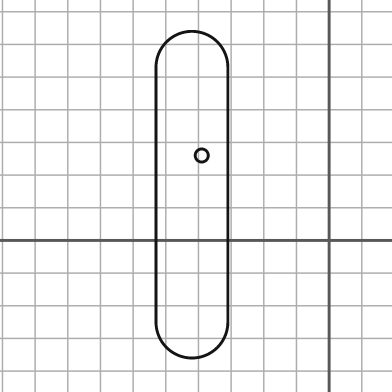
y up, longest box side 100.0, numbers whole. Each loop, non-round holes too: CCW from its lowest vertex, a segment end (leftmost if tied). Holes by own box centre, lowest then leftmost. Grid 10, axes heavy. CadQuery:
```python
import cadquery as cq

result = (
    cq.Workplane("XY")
    .moveTo(-53.0, -25.0)
    .threePointArc((-42.0, -36.0), (-31.0, -25.0))
    .lineTo(-31.0, 53.0)
    .threePointArc((-42.0, 64.0), (-53.0, 53.0))
    .close()
    .moveTo(-39.0, 26.0)
    .circle(2.0)
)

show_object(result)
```